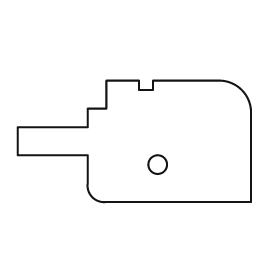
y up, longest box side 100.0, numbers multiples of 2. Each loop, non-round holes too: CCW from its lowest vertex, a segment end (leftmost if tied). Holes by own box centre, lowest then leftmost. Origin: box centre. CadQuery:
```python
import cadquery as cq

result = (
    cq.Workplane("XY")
    .moveTo(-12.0, -26.0)
    .lineTo(50.0, -26.0)
    .lineTo(50.0, 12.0)
    .threePointArc((46.0, 22.0), (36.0, 26.0))
    .lineTo(8.0, 26.0)
    .lineTo(8.0, 22.0)
    .lineTo(2.0, 22.0)
    .lineTo(2.0, 26.0)
    .lineTo(-12.0, 26.0)
    .lineTo(-12.0, 14.0)
    .lineTo(-20.0, 14.0)
    .lineTo(-20.0, 6.0)
    .lineTo(-50.0, 6.0)
    .lineTo(-50.0, -6.0)
    .lineTo(-20.0, -6.0)
    .lineTo(-20.0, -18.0)
    .threePointArc((-18.0, -24.0), (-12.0, -26.0))
    .close()
    .moveTo(10.0, -10.0)
    .circle(4.0)
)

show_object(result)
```